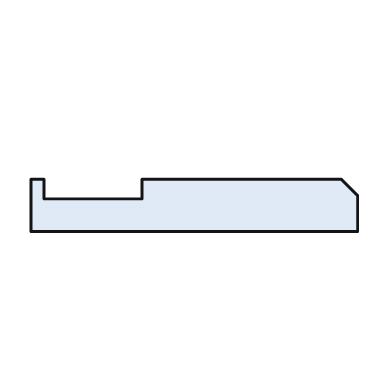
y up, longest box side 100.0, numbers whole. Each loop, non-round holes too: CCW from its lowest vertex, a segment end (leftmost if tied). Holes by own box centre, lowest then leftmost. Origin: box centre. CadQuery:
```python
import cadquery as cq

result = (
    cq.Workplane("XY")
    .moveTo(-50.0, -8.0)
    .lineTo(50.0, -8.0)
    .lineTo(50.0, 3.0)
    .lineTo(45.0, 8.0)
    .lineTo(-16.0, 8.0)
    .lineTo(-16.0, 2.0)
    .lineTo(-46.0, 2.0)
    .lineTo(-46.0, 8.0)
    .lineTo(-50.0, 8.0)
    .close()
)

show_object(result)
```